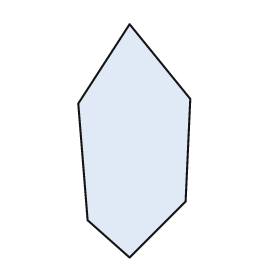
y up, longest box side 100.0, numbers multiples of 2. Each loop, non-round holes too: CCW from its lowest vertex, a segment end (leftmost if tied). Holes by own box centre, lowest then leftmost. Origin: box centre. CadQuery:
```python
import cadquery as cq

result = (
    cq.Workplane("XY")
    .moveTo(-2.0, -50.0)
    .lineTo(22.0, -26.0)
    .lineTo(24.0, 18.0)
    .lineTo(-2.0, 50.0)
    .lineTo(-24.0, 16.0)
    .lineTo(-20.0, -34.0)
    .close()
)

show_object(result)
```